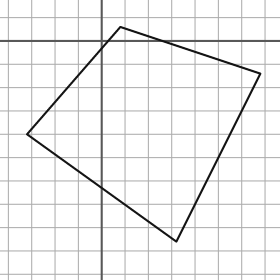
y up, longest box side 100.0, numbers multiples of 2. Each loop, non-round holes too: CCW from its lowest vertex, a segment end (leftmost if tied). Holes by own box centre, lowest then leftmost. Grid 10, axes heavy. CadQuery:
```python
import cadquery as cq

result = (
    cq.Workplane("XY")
    .moveTo(32.0, -86.0)
    .lineTo(68.0, -14.0)
    .lineTo(8.0, 6.0)
    .lineTo(-32.0, -40.0)
    .close()
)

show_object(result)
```